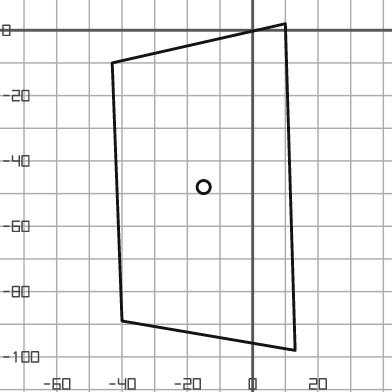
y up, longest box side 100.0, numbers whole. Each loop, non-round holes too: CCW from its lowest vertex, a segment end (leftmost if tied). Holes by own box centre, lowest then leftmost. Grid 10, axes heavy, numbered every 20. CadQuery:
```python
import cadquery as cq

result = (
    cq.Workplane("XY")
    .moveTo(13.0, -98.0)
    .lineTo(10.0, 2.0)
    .lineTo(-43.0, -10.0)
    .lineTo(-40.0, -89.0)
    .close()
    .moveTo(-15.0, -48.0)
    .circle(2.0)
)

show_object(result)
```